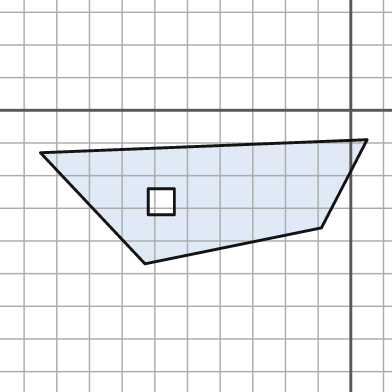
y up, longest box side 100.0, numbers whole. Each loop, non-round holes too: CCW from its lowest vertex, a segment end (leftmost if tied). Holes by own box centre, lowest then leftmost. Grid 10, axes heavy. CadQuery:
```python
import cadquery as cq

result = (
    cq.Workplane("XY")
    .moveTo(-63.0, -47.0)
    .lineTo(-9.0, -36.0)
    .lineTo(5.0, -9.0)
    .lineTo(-95.0, -13.0)
    .close()
    .moveTo(-62.0, -32.0)
    .lineTo(-54.0, -32.0)
    .lineTo(-54.0, -24.0)
    .lineTo(-62.0, -24.0)
    .close()
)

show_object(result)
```